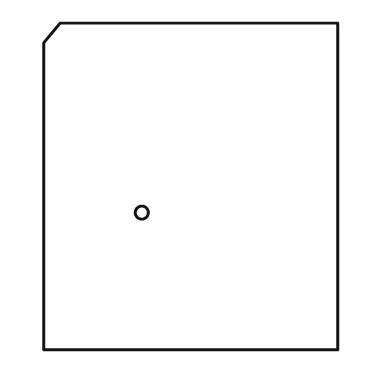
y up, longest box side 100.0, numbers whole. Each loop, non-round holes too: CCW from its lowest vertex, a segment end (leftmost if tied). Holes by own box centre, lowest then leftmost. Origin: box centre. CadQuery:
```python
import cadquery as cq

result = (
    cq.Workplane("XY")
    .moveTo(-45.0, -50.0)
    .lineTo(45.0, -50.0)
    .lineTo(45.0, 50.0)
    .lineTo(-40.0, 50.0)
    .lineTo(-45.0, 44.0)
    .close()
    .moveTo(-15.0, -8.0)
    .circle(2.0)
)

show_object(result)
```